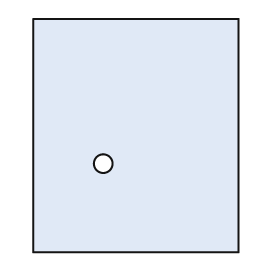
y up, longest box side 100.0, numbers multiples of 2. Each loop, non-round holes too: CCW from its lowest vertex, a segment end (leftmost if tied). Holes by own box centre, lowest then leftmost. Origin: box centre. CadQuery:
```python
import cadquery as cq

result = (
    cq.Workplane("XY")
    .moveTo(-44.0, -50.0)
    .lineTo(44.0, -50.0)
    .lineTo(44.0, 50.0)
    .lineTo(-44.0, 50.0)
    .close()
    .moveTo(-14.0, -12.0)
    .circle(4.0)
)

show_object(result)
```